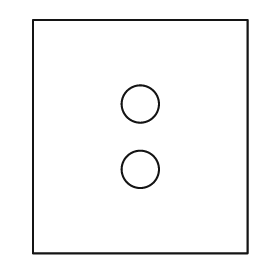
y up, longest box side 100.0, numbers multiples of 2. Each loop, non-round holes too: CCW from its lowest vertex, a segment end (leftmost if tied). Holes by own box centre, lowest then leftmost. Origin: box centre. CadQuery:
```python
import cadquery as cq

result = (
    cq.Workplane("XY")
    .moveTo(-46.0, -50.0)
    .lineTo(46.0, -50.0)
    .lineTo(46.0, 50.0)
    .lineTo(-46.0, 50.0)
    .close()
    .moveTo(0.0, -14.0)
    .circle(8.0)
    .moveTo(0.0, 14.0)
    .circle(8.0)
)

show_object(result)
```